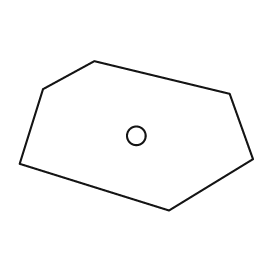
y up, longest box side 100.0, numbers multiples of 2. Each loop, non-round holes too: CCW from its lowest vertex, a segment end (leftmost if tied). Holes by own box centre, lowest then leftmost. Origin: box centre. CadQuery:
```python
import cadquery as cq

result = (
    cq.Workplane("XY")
    .moveTo(14.0, -32.0)
    .lineTo(50.0, -10.0)
    .lineTo(40.0, 18.0)
    .lineTo(-18.0, 32.0)
    .lineTo(-40.0, 20.0)
    .lineTo(-50.0, -12.0)
    .close()
    .moveTo(0.0, 0.0)
    .circle(4.0)
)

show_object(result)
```